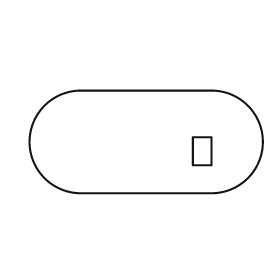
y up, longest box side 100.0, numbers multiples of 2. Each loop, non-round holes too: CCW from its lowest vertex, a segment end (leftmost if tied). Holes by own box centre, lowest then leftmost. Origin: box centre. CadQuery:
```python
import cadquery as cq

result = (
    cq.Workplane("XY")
    .moveTo(-28.0, -22.0)
    .lineTo(28.0, -22.0)
    .threePointArc((50.0, 0.0), (28.0, 22.0))
    .lineTo(-28.0, 22.0)
    .threePointArc((-50.0, 0.0), (-28.0, -22.0))
    .close()
    .moveTo(20.0, -10.0)
    .lineTo(28.0, -10.0)
    .lineTo(28.0, 2.0)
    .lineTo(20.0, 2.0)
    .close()
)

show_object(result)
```